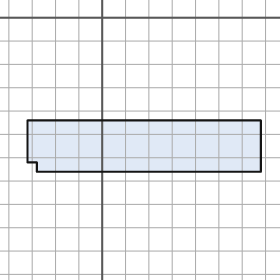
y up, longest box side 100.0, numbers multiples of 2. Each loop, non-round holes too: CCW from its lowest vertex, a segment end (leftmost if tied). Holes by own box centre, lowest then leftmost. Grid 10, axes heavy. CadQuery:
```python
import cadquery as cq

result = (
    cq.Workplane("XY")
    .moveTo(-28.0, -66.0)
    .lineTo(68.0, -66.0)
    .lineTo(68.0, -44.0)
    .lineTo(-32.0, -44.0)
    .lineTo(-32.0, -62.0)
    .lineTo(-28.0, -62.0)
    .close()
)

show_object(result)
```